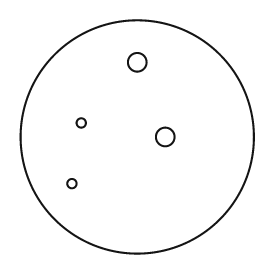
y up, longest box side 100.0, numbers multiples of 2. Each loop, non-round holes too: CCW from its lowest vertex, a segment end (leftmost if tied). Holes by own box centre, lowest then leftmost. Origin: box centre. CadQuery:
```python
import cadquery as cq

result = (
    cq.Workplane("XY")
    .moveTo(0.0, 0.0)
    .circle(50.0)
    .moveTo(-28.0, -20.0)
    .circle(2.0)
    .moveTo(12.0, 0.0)
    .circle(4.0)
    .moveTo(-24.0, 6.0)
    .circle(2.0)
    .moveTo(0.0, 32.0)
    .circle(4.0)
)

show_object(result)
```